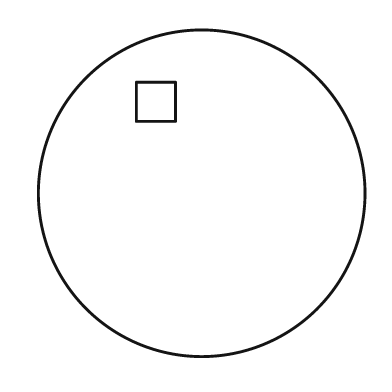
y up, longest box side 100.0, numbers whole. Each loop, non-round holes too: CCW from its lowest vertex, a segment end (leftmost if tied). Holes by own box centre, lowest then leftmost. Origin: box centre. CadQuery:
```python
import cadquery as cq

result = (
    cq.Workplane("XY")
    .moveTo(0.0, 0.0)
    .circle(50.0)
    .moveTo(-20.0, 22.0)
    .lineTo(-8.0, 22.0)
    .lineTo(-8.0, 34.0)
    .lineTo(-20.0, 34.0)
    .close()
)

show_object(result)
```